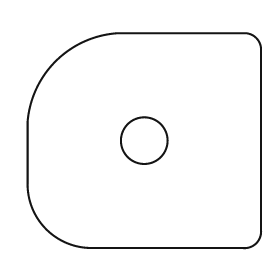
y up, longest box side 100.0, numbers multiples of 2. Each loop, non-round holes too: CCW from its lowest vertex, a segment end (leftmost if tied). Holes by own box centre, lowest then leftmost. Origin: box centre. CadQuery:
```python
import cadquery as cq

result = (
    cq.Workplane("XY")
    .moveTo(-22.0, -46.0)
    .lineTo(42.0, -46.0)
    .threePointArc((48.0, -44.0), (50.0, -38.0))
    .lineTo(50.0, 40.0)
    .threePointArc((48.0, 44.0), (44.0, 46.0))
    .lineTo(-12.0, 46.0)
    .threePointArc((-38.0, 34.0), (-50.0, 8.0))
    .lineTo(-50.0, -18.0)
    .threePointArc((-42.0, -38.0), (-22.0, -46.0))
    .close()
    .moveTo(0.0, 0.0)
    .circle(10.0)
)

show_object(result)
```